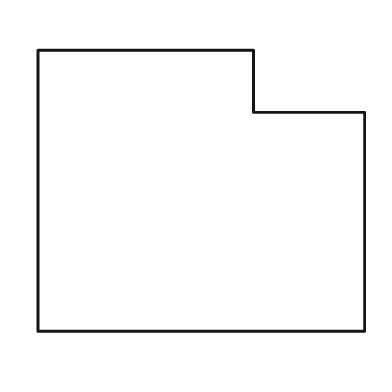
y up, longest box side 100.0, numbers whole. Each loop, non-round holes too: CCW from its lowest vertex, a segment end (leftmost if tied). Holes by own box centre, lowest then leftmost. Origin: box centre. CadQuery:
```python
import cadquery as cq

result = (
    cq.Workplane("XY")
    .moveTo(-50.0, -43.0)
    .lineTo(50.0, -43.0)
    .lineTo(50.0, 24.0)
    .lineTo(16.0, 24.0)
    .lineTo(16.0, 43.0)
    .lineTo(-50.0, 43.0)
    .close()
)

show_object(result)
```